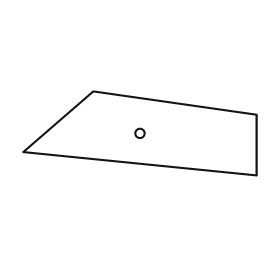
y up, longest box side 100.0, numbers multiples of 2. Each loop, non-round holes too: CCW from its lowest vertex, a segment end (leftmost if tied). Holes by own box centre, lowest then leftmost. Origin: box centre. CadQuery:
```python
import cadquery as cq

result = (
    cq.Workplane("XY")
    .moveTo(50.0, -18.0)
    .lineTo(50.0, 8.0)
    .lineTo(-20.0, 18.0)
    .lineTo(-50.0, -8.0)
    .close()
    .moveTo(0.0, 0.0)
    .circle(2.0)
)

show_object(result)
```